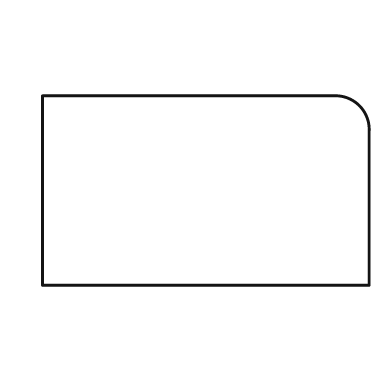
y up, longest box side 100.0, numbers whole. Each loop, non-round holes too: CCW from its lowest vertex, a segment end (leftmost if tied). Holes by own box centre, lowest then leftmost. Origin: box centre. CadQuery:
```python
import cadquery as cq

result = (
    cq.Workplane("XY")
    .moveTo(-50.0, -29.0)
    .lineTo(50.0, -29.0)
    .lineTo(50.0, 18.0)
    .threePointArc((47.0, 26.0), (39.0, 29.0))
    .lineTo(-50.0, 29.0)
    .close()
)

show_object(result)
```